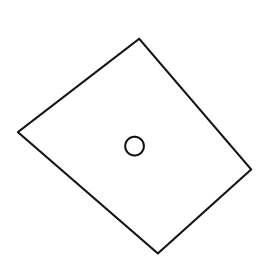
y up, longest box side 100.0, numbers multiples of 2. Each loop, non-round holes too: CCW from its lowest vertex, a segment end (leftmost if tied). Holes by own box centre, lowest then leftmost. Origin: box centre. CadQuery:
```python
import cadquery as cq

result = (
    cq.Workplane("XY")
    .moveTo(10.0, -46.0)
    .lineTo(50.0, -10.0)
    .lineTo(2.0, 46.0)
    .lineTo(-50.0, 6.0)
    .close()
    .moveTo(0.0, 0.0)
    .circle(4.0)
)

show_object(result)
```